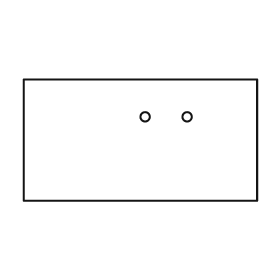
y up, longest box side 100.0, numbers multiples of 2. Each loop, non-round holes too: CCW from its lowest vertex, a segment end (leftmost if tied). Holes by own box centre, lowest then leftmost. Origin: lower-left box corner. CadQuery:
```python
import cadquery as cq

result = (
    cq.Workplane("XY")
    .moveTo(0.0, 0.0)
    .lineTo(100.0, 0.0)
    .lineTo(100.0, 52.0)
    .lineTo(0.0, 52.0)
    .close()
    .moveTo(52.0, 36.0)
    .circle(2.0)
    .moveTo(70.0, 36.0)
    .circle(2.0)
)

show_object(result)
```